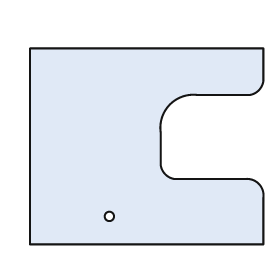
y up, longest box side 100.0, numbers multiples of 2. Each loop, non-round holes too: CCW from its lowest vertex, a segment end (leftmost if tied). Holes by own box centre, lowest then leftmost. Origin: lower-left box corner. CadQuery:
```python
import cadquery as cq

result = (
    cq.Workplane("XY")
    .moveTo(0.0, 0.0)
    .lineTo(100.0, 0.0)
    .lineTo(100.0, 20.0)
    .threePointArc((98.0, 26.0), (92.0, 28.0))
    .lineTo(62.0, 28.0)
    .threePointArc((58.0, 30.0), (56.0, 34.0))
    .lineTo(56.0, 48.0)
    .threePointArc((60.0, 60.0), (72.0, 64.0))
    .lineTo(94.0, 64.0)
    .threePointArc((98.0, 66.0), (100.0, 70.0))
    .lineTo(100.0, 84.0)
    .lineTo(0.0, 84.0)
    .close()
    .moveTo(34.0, 12.0)
    .circle(2.0)
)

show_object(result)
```